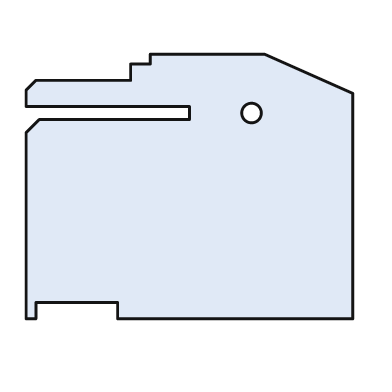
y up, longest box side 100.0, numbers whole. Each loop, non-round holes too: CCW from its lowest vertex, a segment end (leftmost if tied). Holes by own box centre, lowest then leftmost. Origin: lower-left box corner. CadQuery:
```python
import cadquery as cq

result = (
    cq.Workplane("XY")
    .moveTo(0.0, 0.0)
    .lineTo(3.0, 0.0)
    .lineTo(3.0, 5.0)
    .lineTo(28.0, 5.0)
    .lineTo(28.0, 0.0)
    .lineTo(100.0, 0.0)
    .lineTo(100.0, 69.0)
    .lineTo(73.0, 81.0)
    .lineTo(38.0, 81.0)
    .lineTo(38.0, 78.0)
    .lineTo(32.0, 78.0)
    .lineTo(32.0, 73.0)
    .lineTo(3.0, 73.0)
    .lineTo(0.0, 70.0)
    .lineTo(0.0, 65.0)
    .lineTo(50.0, 65.0)
    .lineTo(50.0, 61.0)
    .lineTo(4.0, 61.0)
    .lineTo(0.0, 57.0)
    .close()
    .moveTo(69.0, 63.0)
    .circle(3.0)
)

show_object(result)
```